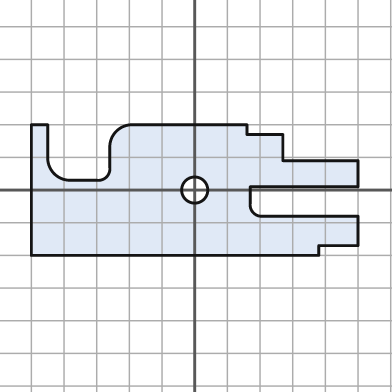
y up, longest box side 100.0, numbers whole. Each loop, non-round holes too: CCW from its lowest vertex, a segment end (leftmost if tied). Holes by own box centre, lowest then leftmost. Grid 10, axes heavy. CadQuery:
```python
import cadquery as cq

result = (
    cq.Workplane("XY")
    .moveTo(-50.0, -20.0)
    .lineTo(38.0, -20.0)
    .lineTo(38.0, -17.0)
    .lineTo(50.0, -17.0)
    .lineTo(50.0, -8.0)
    .lineTo(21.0, -8.0)
    .threePointArc((18.0, -7.0), (17.0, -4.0))
    .lineTo(17.0, 1.0)
    .lineTo(50.0, 1.0)
    .lineTo(50.0, 9.0)
    .lineTo(27.0, 9.0)
    .lineTo(27.0, 17.0)
    .lineTo(16.0, 17.0)
    .lineTo(16.0, 20.0)
    .lineTo(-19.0, 20.0)
    .threePointArc((-24.0, 18.0), (-26.0, 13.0))
    .lineTo(-26.0, 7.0)
    .threePointArc((-27.0, 4.0), (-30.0, 3.0))
    .lineTo(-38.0, 3.0)
    .threePointArc((-43.0, 5.0), (-45.0, 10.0))
    .lineTo(-45.0, 20.0)
    .lineTo(-50.0, 20.0)
    .close()
    .moveTo(0.0, 0.0)
    .circle(4.0)
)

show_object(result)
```